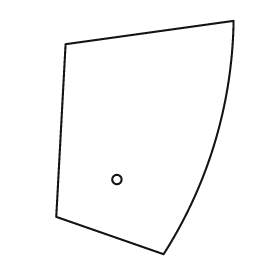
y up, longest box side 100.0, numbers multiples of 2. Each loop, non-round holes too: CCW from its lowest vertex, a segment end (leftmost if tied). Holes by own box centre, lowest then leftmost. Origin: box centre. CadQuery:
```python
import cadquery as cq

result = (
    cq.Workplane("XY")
    .moveTo(8.0, -50.0)
    .threePointArc((30.0, -2.0), (38.0, 50.0))
    .lineTo(-34.0, 40.0)
    .lineTo(-38.0, -34.0)
    .close()
    .moveTo(-12.0, -18.0)
    .circle(2.0)
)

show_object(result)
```